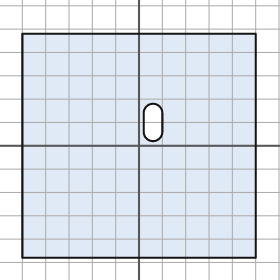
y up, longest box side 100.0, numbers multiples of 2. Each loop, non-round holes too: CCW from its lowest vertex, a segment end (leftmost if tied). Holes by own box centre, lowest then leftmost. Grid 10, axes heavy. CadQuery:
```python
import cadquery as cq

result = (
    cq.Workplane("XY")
    .moveTo(-50.0, -48.0)
    .lineTo(50.0, -48.0)
    .lineTo(50.0, 48.0)
    .lineTo(-50.0, 48.0)
    .close()
    .moveTo(2.0, 6.0)
    .threePointArc((6.0, 2.0), (10.0, 6.0))
    .lineTo(10.0, 14.0)
    .threePointArc((6.0, 18.0), (2.0, 14.0))
    .close()
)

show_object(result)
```